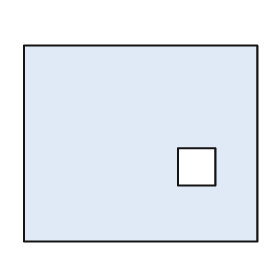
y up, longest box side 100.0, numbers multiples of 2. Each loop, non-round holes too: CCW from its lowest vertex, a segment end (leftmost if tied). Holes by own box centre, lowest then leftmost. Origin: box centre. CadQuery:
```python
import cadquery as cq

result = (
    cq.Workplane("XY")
    .moveTo(-50.0, -42.0)
    .lineTo(50.0, -42.0)
    .lineTo(50.0, 42.0)
    .lineTo(-50.0, 42.0)
    .close()
    .moveTo(16.0, -18.0)
    .lineTo(32.0, -18.0)
    .lineTo(32.0, -2.0)
    .lineTo(16.0, -2.0)
    .close()
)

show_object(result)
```